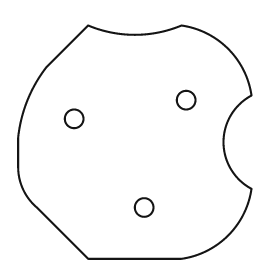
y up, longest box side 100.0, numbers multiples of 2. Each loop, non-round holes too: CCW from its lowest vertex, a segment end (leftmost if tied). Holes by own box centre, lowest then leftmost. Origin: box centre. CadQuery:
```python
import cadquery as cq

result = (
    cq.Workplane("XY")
    .moveTo(-20.0, -50.0)
    .lineTo(20.0, -50.0)
    .threePointArc((40.0, -40.0), (50.0, -20.0))
    .threePointArc((38.0, 0.0), (50.0, 20.0))
    .threePointArc((40.0, 40.0), (20.0, 50.0))
    .threePointArc((0.0, 46.0), (-20.0, 50.0))
    .lineTo(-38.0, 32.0)
    .threePointArc((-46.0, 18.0), (-50.0, 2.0))
    .lineTo(-50.0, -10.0)
    .threePointArc((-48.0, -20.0), (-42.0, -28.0))
    .close()
    .moveTo(4.0, -28.0)
    .circle(4.0)
    .moveTo(-26.0, 10.0)
    .circle(4.0)
    .moveTo(22.0, 18.0)
    .circle(4.0)
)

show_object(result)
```